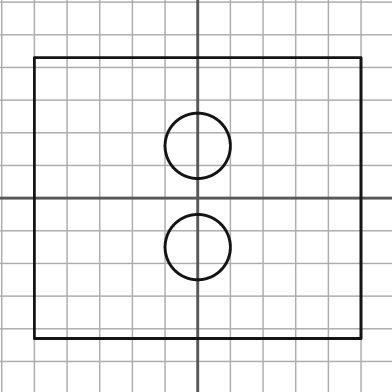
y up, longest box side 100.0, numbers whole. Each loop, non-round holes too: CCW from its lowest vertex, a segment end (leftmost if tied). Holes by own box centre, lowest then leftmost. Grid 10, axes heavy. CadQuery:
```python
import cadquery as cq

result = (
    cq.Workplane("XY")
    .moveTo(-50.0, -43.0)
    .lineTo(50.0, -43.0)
    .lineTo(50.0, 43.0)
    .lineTo(-50.0, 43.0)
    .close()
    .moveTo(0.0, -15.0)
    .circle(10.0)
    .moveTo(0.0, 16.0)
    .circle(10.0)
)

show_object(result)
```